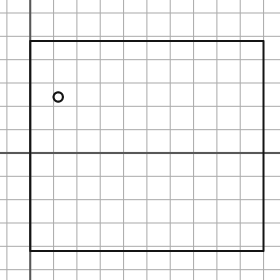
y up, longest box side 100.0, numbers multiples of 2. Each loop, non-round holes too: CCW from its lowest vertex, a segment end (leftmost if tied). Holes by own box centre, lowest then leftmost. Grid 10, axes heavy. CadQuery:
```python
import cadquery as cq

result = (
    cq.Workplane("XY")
    .moveTo(0.0, -42.0)
    .lineTo(100.0, -42.0)
    .lineTo(100.0, 48.0)
    .lineTo(0.0, 48.0)
    .close()
    .moveTo(12.0, 24.0)
    .circle(2.0)
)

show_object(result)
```